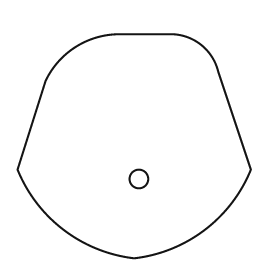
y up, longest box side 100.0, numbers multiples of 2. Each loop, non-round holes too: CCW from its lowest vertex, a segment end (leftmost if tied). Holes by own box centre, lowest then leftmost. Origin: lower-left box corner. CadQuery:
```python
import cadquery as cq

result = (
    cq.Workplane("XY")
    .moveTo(50.0, 0.0)
    .threePointArc((80.0, 12.0), (100.0, 38.0))
    .lineTo(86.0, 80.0)
    .threePointArc((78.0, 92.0), (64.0, 96.0))
    .lineTo(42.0, 96.0)
    .threePointArc((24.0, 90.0), (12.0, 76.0))
    .lineTo(0.0, 38.0)
    .threePointArc((20.0, 12.0), (50.0, 0.0))
    .close()
    .moveTo(52.0, 34.0)
    .circle(4.0)
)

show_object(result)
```